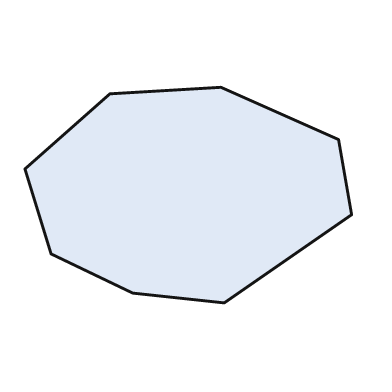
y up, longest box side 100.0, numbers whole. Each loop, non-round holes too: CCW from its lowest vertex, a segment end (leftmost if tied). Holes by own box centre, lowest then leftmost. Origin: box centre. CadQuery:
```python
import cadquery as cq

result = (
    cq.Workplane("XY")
    .moveTo(11.0, -33.0)
    .lineTo(50.0, -6.0)
    .lineTo(46.0, 17.0)
    .lineTo(10.0, 33.0)
    .lineTo(-24.0, 31.0)
    .lineTo(-50.0, 8.0)
    .lineTo(-42.0, -18.0)
    .lineTo(-17.0, -30.0)
    .close()
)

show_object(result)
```